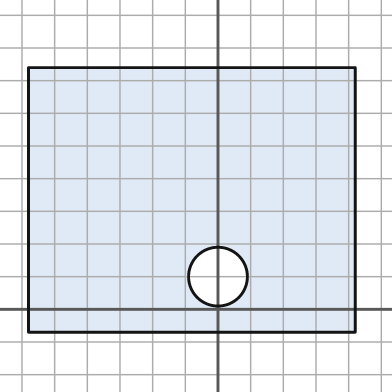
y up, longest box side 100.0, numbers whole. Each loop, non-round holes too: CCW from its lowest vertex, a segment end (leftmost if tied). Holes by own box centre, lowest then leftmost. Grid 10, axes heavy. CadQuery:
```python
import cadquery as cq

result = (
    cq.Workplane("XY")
    .moveTo(-58.0, -7.0)
    .lineTo(42.0, -7.0)
    .lineTo(42.0, 74.0)
    .lineTo(-58.0, 74.0)
    .close()
    .moveTo(0.0, 10.0)
    .circle(9.0)
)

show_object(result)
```